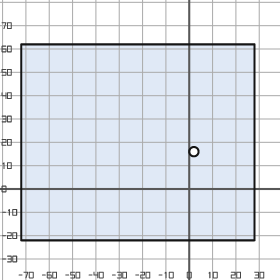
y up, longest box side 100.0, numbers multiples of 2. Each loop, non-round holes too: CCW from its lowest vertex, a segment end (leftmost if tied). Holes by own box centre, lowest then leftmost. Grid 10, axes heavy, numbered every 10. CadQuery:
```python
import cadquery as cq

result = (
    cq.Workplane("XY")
    .moveTo(-72.0, -22.0)
    .lineTo(28.0, -22.0)
    .lineTo(28.0, 62.0)
    .lineTo(-72.0, 62.0)
    .close()
    .moveTo(2.0, 16.0)
    .circle(2.0)
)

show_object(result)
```